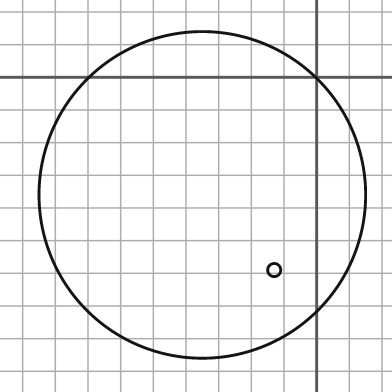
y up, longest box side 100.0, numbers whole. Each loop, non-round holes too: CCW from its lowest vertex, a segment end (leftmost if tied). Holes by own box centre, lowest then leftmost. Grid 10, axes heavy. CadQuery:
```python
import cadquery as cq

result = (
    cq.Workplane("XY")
    .moveTo(-35.0, -36.0)
    .circle(50.0)
    .moveTo(-13.0, -59.0)
    .circle(2.0)
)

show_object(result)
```